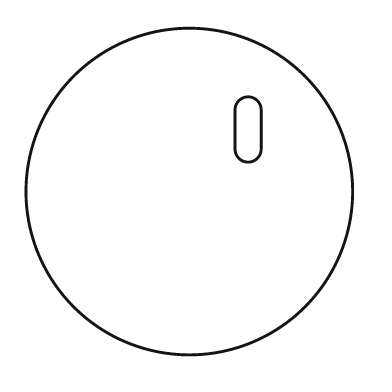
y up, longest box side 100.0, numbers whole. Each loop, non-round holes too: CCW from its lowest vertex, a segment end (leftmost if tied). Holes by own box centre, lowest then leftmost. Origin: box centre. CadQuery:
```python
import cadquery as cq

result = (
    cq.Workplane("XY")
    .moveTo(0.0, 0.0)
    .circle(50.0)
    .moveTo(14.0, 13.0)
    .threePointArc((18.0, 9.0), (22.0, 13.0))
    .lineTo(22.0, 25.0)
    .threePointArc((18.0, 29.0), (14.0, 25.0))
    .close()
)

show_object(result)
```